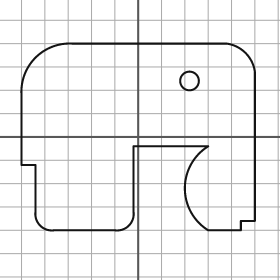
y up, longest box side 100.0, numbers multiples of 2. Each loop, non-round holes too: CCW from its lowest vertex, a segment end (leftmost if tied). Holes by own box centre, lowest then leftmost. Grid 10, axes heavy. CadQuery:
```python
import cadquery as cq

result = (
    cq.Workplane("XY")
    .moveTo(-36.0, -40.0)
    .lineTo(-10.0, -40.0)
    .threePointArc((-4.0, -38.0), (-2.0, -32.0))
    .lineTo(-2.0, -4.0)
    .lineTo(30.0, -4.0)
    .threePointArc((20.0, -22.0), (30.0, -40.0))
    .lineTo(44.0, -40.0)
    .lineTo(44.0, -36.0)
    .lineTo(50.0, -36.0)
    .lineTo(50.0, 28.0)
    .threePointArc((46.0, 36.0), (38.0, 40.0))
    .lineTo(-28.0, 40.0)
    .threePointArc((-44.0, 34.0), (-50.0, 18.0))
    .lineTo(-50.0, -12.0)
    .lineTo(-44.0, -12.0)
    .lineTo(-44.0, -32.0)
    .threePointArc((-42.0, -38.0), (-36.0, -40.0))
    .close()
    .moveTo(22.0, 24.0)
    .circle(4.0)
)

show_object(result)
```